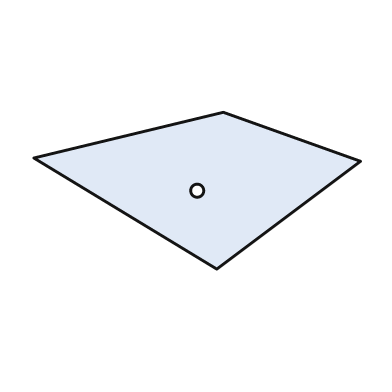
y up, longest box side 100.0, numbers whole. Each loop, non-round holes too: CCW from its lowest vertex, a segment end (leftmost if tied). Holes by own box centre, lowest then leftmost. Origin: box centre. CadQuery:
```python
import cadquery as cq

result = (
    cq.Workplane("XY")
    .moveTo(6.0, -24.0)
    .lineTo(50.0, 9.0)
    .lineTo(8.0, 24.0)
    .lineTo(-50.0, 10.0)
    .close()
    .moveTo(0.0, 0.0)
    .circle(2.0)
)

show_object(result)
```